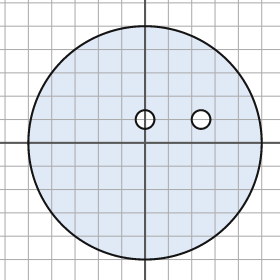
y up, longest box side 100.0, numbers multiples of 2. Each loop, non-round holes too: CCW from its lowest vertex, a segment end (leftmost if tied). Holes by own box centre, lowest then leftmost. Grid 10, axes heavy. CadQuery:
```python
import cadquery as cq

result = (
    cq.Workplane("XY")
    .moveTo(0.0, 0.0)
    .circle(50.0)
    .moveTo(0.0, 10.0)
    .circle(4.0)
    .moveTo(24.0, 10.0)
    .circle(4.0)
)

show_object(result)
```